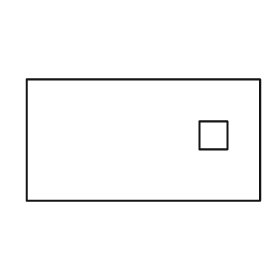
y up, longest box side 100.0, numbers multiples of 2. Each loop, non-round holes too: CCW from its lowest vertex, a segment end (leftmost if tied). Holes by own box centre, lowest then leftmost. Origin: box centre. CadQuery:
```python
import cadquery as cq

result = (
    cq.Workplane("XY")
    .moveTo(-50.0, -26.0)
    .lineTo(50.0, -26.0)
    .lineTo(50.0, 26.0)
    .lineTo(-50.0, 26.0)
    .close()
    .moveTo(24.0, -4.0)
    .lineTo(36.0, -4.0)
    .lineTo(36.0, 8.0)
    .lineTo(24.0, 8.0)
    .close()
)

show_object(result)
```